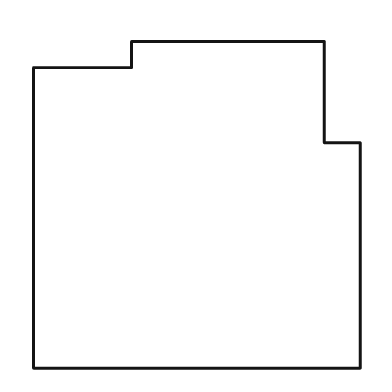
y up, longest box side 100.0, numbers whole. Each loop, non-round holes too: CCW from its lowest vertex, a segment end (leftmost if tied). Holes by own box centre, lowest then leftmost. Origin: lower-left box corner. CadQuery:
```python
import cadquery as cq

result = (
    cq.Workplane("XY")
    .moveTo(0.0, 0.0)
    .lineTo(100.0, 0.0)
    .lineTo(100.0, 69.0)
    .lineTo(89.0, 69.0)
    .lineTo(89.0, 100.0)
    .lineTo(30.0, 100.0)
    .lineTo(30.0, 92.0)
    .lineTo(0.0, 92.0)
    .close()
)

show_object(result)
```